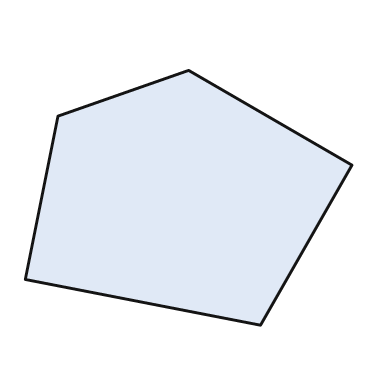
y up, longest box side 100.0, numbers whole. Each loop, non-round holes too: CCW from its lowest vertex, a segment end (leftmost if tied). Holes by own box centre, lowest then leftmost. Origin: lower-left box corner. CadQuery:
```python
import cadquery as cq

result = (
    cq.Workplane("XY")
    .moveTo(72.0, 0.0)
    .lineTo(100.0, 49.0)
    .lineTo(50.0, 78.0)
    .lineTo(10.0, 64.0)
    .lineTo(0.0, 14.0)
    .close()
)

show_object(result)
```